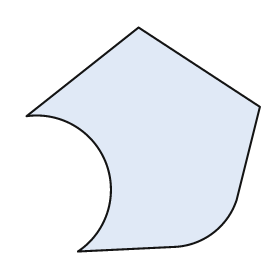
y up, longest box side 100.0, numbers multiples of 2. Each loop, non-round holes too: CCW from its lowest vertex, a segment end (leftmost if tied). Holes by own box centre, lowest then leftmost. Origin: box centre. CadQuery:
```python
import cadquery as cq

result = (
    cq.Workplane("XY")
    .moveTo(-28.0, -48.0)
    .lineTo(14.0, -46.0)
    .threePointArc((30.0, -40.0), (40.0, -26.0))
    .lineTo(50.0, 14.0)
    .lineTo(-2.0, 48.0)
    .lineTo(-50.0, 10.0)
    .threePointArc((-16.0, -10.0), (-28.0, -48.0))
    .close()
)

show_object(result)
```